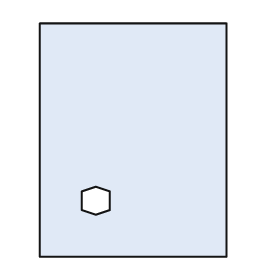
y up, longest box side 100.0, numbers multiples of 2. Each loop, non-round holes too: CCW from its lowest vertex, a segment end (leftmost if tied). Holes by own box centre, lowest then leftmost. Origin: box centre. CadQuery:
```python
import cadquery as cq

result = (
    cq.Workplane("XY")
    .moveTo(-40.0, -50.0)
    .lineTo(40.0, -50.0)
    .lineTo(40.0, 50.0)
    .lineTo(-40.0, 50.0)
    .close()
    .moveTo(-16.0, -32.0)
    .lineTo(-10.0, -30.0)
    .lineTo(-10.0, -22.0)
    .lineTo(-16.0, -20.0)
    .lineTo(-22.0, -22.0)
    .lineTo(-22.0, -30.0)
    .close()
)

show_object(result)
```